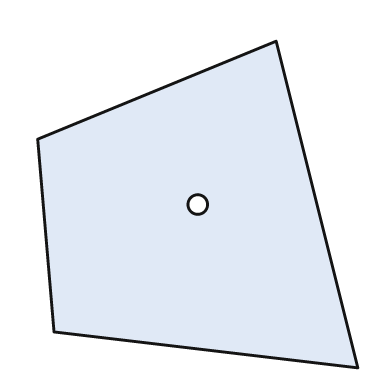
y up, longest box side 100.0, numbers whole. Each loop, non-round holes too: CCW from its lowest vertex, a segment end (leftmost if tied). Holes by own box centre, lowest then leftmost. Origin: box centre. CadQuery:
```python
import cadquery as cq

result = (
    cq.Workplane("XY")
    .moveTo(49.0, -50.0)
    .lineTo(24.0, 50.0)
    .lineTo(-49.0, 20.0)
    .lineTo(-44.0, -39.0)
    .close()
    .moveTo(0.0, 0.0)
    .circle(3.0)
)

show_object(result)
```